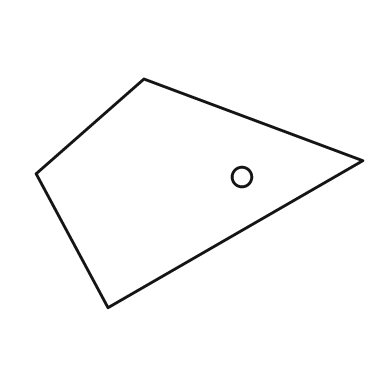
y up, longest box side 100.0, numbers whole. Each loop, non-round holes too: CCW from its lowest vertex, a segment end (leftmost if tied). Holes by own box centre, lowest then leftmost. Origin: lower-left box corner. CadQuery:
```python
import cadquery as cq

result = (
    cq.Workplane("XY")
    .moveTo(22.0, 0.0)
    .lineTo(100.0, 45.0)
    .lineTo(33.0, 70.0)
    .lineTo(0.0, 41.0)
    .close()
    .moveTo(63.0, 40.0)
    .circle(3.0)
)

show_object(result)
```